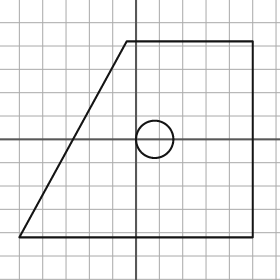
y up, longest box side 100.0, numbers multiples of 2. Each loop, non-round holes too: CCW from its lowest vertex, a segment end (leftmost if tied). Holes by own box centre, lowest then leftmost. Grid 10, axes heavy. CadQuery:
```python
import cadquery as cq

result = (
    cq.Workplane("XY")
    .moveTo(-50.0, -42.0)
    .lineTo(50.0, -42.0)
    .lineTo(50.0, 42.0)
    .lineTo(-4.0, 42.0)
    .close()
    .moveTo(8.0, 0.0)
    .circle(8.0)
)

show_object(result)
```